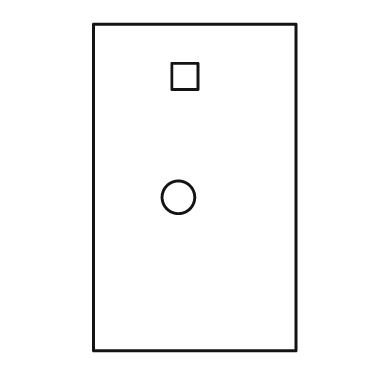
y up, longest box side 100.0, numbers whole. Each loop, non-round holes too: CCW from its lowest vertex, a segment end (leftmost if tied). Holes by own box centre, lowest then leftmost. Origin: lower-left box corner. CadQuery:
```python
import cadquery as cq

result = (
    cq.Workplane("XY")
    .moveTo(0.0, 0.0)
    .lineTo(62.0, 0.0)
    .lineTo(62.0, 100.0)
    .lineTo(0.0, 100.0)
    .close()
    .moveTo(26.0, 47.0)
    .circle(5.0)
    .moveTo(24.0, 80.0)
    .lineTo(32.0, 80.0)
    .lineTo(32.0, 88.0)
    .lineTo(24.0, 88.0)
    .close()
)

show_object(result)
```